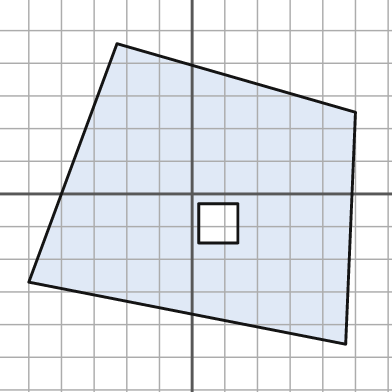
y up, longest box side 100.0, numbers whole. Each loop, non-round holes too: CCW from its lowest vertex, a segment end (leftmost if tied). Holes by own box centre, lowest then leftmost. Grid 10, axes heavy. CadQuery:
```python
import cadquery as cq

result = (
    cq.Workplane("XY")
    .moveTo(47.0, -46.0)
    .lineTo(50.0, 25.0)
    .lineTo(-23.0, 46.0)
    .lineTo(-50.0, -27.0)
    .close()
    .moveTo(2.0, -15.0)
    .lineTo(14.0, -15.0)
    .lineTo(14.0, -3.0)
    .lineTo(2.0, -3.0)
    .close()
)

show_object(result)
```